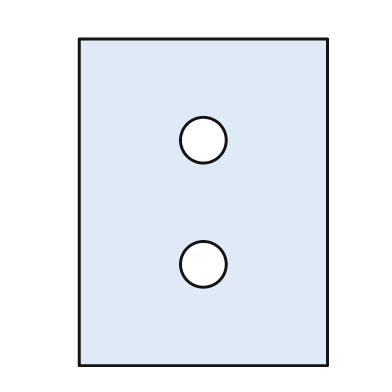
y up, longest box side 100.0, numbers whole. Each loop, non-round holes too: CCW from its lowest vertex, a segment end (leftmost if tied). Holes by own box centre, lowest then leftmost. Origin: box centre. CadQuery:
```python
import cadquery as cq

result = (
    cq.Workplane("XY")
    .moveTo(-38.0, -50.0)
    .lineTo(38.0, -50.0)
    .lineTo(38.0, 50.0)
    .lineTo(-38.0, 50.0)
    .close()
    .moveTo(0.0, -19.0)
    .circle(7.0)
    .moveTo(0.0, 19.0)
    .circle(7.0)
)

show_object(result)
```